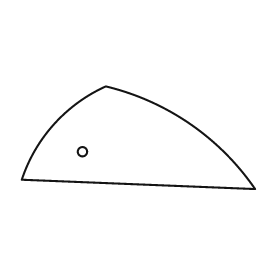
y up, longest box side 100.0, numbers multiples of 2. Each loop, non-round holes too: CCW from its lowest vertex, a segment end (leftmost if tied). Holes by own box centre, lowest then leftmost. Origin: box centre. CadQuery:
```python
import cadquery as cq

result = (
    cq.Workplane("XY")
    .moveTo(50.0, -22.0)
    .threePointArc((22.0, 6.0), (-14.0, 22.0))
    .threePointArc((-36.0, 6.0), (-50.0, -18.0))
    .close()
    .moveTo(-24.0, -6.0)
    .circle(2.0)
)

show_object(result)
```